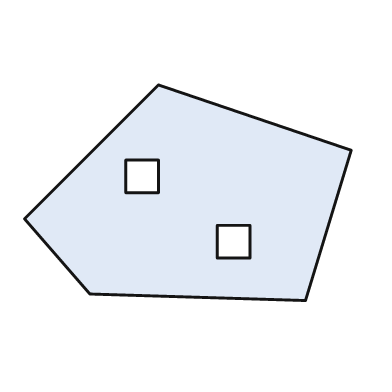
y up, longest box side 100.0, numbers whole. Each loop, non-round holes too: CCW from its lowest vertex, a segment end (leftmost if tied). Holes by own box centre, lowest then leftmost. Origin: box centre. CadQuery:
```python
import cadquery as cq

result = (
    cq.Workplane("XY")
    .moveTo(36.0, -33.0)
    .lineTo(50.0, 13.0)
    .lineTo(-9.0, 33.0)
    .lineTo(-50.0, -8.0)
    .lineTo(-30.0, -31.0)
    .close()
    .moveTo(9.0, -20.0)
    .lineTo(19.0, -20.0)
    .lineTo(19.0, -10.0)
    .lineTo(9.0, -10.0)
    .close()
    .moveTo(-19.0, 0.0)
    .lineTo(-9.0, 0.0)
    .lineTo(-9.0, 10.0)
    .lineTo(-19.0, 10.0)
    .close()
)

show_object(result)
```